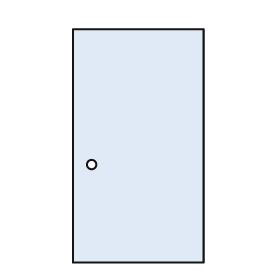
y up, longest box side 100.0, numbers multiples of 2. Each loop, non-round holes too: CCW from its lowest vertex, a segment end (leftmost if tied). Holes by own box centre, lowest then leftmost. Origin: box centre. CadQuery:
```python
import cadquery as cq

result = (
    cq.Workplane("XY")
    .moveTo(-28.0, -50.0)
    .lineTo(28.0, -50.0)
    .lineTo(28.0, 50.0)
    .lineTo(-28.0, 50.0)
    .close()
    .moveTo(-20.0, -8.0)
    .circle(2.0)
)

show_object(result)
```